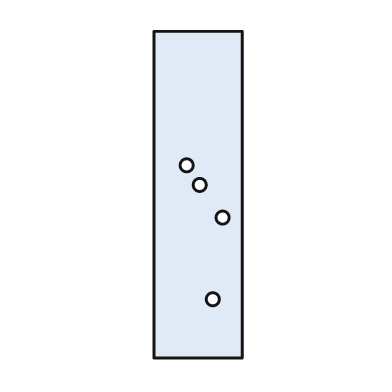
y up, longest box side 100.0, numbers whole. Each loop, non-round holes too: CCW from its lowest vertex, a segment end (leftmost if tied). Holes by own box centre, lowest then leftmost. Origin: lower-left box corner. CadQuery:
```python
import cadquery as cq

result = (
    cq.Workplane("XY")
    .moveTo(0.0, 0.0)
    .lineTo(27.0, 0.0)
    .lineTo(27.0, 100.0)
    .lineTo(0.0, 100.0)
    .close()
    .moveTo(18.0, 18.0)
    .circle(2.0)
    .moveTo(21.0, 43.0)
    .circle(2.0)
    .moveTo(14.0, 53.0)
    .circle(2.0)
    .moveTo(10.0, 59.0)
    .circle(2.0)
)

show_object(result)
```